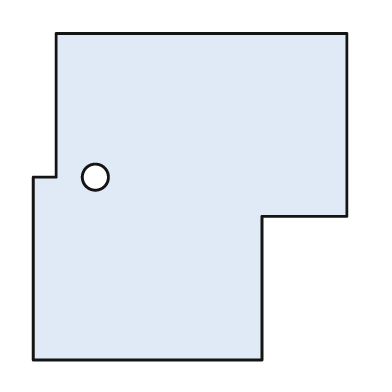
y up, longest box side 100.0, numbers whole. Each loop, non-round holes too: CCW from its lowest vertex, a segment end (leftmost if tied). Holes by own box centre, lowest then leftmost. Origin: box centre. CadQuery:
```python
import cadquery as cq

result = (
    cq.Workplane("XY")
    .moveTo(-48.0, -50.0)
    .lineTo(22.0, -50.0)
    .lineTo(22.0, -6.0)
    .lineTo(48.0, -6.0)
    .lineTo(48.0, 50.0)
    .lineTo(-41.0, 50.0)
    .lineTo(-41.0, 6.0)
    .lineTo(-48.0, 6.0)
    .close()
    .moveTo(-29.0, 6.0)
    .circle(4.0)
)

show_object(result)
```